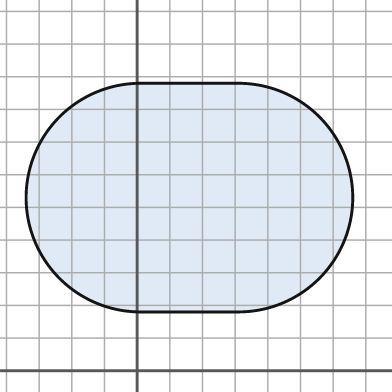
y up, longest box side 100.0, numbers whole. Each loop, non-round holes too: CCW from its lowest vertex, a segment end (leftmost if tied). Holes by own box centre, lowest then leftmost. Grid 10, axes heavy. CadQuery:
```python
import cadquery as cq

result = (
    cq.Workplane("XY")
    .moveTo(1.0, 18.0)
    .lineTo(31.0, 18.0)
    .threePointArc((66.0, 53.0), (31.0, 88.0))
    .lineTo(1.0, 88.0)
    .threePointArc((-34.0, 53.0), (1.0, 18.0))
    .close()
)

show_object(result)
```